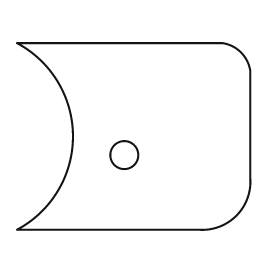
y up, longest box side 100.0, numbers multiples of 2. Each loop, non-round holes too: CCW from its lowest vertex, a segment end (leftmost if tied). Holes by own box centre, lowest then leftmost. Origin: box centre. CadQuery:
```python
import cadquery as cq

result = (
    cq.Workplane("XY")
    .moveTo(-50.0, -40.0)
    .lineTo(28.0, -40.0)
    .threePointArc((44.0, -34.0), (50.0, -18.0))
    .lineTo(50.0, 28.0)
    .threePointArc((46.0, 36.0), (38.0, 40.0))
    .lineTo(-50.0, 40.0)
    .threePointArc((-26.0, 0.0), (-50.0, -40.0))
    .close()
    .moveTo(-4.0, -8.0)
    .circle(6.0)
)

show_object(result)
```